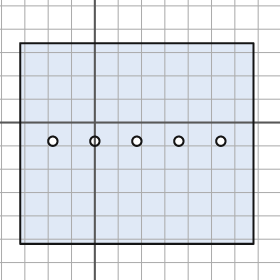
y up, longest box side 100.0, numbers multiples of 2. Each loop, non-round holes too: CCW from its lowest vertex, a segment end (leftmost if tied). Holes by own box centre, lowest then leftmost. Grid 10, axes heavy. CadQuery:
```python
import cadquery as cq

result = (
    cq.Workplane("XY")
    .moveTo(-32.0, -52.0)
    .lineTo(68.0, -52.0)
    .lineTo(68.0, 34.0)
    .lineTo(-32.0, 34.0)
    .close()
    .moveTo(-18.0, -8.0)
    .circle(2.0)
    .moveTo(0.0, -8.0)
    .circle(2.0)
    .moveTo(18.0, -8.0)
    .circle(2.0)
    .moveTo(36.0, -8.0)
    .circle(2.0)
    .moveTo(54.0, -8.0)
    .circle(2.0)
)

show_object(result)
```